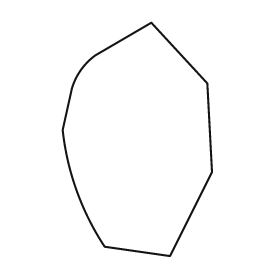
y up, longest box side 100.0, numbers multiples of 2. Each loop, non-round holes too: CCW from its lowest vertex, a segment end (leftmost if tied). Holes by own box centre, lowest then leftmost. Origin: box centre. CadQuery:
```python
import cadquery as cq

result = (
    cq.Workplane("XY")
    .moveTo(14.0, -50.0)
    .lineTo(32.0, -14.0)
    .lineTo(30.0, 24.0)
    .lineTo(6.0, 50.0)
    .lineTo(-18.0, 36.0)
    .threePointArc((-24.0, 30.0), (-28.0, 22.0))
    .lineTo(-32.0, 4.0)
    .threePointArc((-26.0, -22.0), (-14.0, -46.0))
    .close()
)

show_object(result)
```